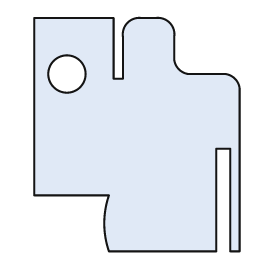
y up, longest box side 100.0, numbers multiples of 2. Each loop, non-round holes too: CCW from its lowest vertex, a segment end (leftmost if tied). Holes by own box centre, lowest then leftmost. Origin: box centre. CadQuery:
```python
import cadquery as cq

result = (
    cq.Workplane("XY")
    .moveTo(-12.0, -50.0)
    .lineTo(34.0, -50.0)
    .lineTo(34.0, -6.0)
    .lineTo(40.0, -6.0)
    .lineTo(40.0, -50.0)
    .lineTo(44.0, -50.0)
    .lineTo(44.0, 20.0)
    .threePointArc((42.0, 24.0), (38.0, 26.0))
    .lineTo(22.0, 26.0)
    .threePointArc((18.0, 28.0), (16.0, 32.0))
    .lineTo(16.0, 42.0)
    .threePointArc((14.0, 48.0), (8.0, 50.0))
    .lineTo(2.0, 50.0)
    .threePointArc((-4.0, 48.0), (-6.0, 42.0))
    .lineTo(-6.0, 24.0)
    .lineTo(-10.0, 24.0)
    .lineTo(-10.0, 50.0)
    .lineTo(-44.0, 50.0)
    .lineTo(-44.0, -26.0)
    .lineTo(-12.0, -26.0)
    .threePointArc((-14.0, -38.0), (-12.0, -50.0))
    .close()
    .moveTo(-30.0, 26.0)
    .circle(8.0)
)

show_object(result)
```